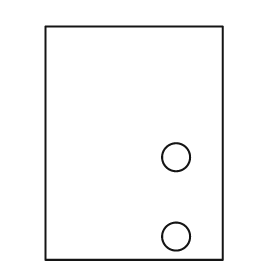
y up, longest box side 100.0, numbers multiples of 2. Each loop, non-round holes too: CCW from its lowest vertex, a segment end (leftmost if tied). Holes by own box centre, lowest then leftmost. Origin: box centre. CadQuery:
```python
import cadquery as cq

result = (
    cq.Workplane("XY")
    .moveTo(-38.0, -50.0)
    .lineTo(38.0, -50.0)
    .lineTo(38.0, 50.0)
    .lineTo(-38.0, 50.0)
    .close()
    .moveTo(18.0, -40.0)
    .circle(6.0)
    .moveTo(18.0, -6.0)
    .circle(6.0)
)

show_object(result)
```